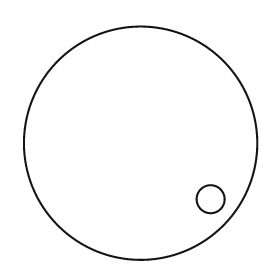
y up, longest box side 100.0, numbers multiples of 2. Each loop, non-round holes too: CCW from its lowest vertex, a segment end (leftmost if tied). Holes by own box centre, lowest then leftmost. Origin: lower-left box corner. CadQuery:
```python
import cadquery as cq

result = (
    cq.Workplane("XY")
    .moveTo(50.0, 50.0)
    .circle(50.0)
    .moveTo(80.0, 26.0)
    .circle(6.0)
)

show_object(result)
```